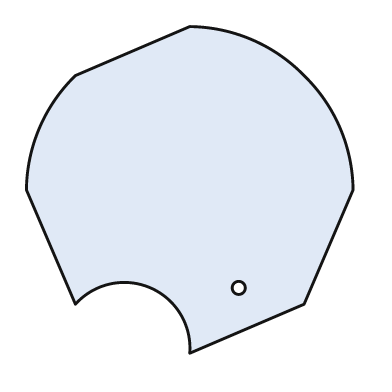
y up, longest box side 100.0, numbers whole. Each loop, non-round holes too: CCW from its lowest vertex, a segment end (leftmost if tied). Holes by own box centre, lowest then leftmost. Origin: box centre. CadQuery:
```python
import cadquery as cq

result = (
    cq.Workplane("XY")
    .moveTo(0.0, -50.0)
    .lineTo(35.0, -35.0)
    .lineTo(50.0, 0.0)
    .threePointArc((46.0, 19.0), (35.0, 35.0))
    .threePointArc((19.0, 46.0), (0.0, 50.0))
    .lineTo(-35.0, 35.0)
    .threePointArc((-46.0, 19.0), (-50.0, 0.0))
    .lineTo(-35.0, -35.0)
    .threePointArc((-12.0, -30.0), (0.0, -50.0))
    .close()
    .moveTo(15.0, -30.0)
    .circle(2.0)
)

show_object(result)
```